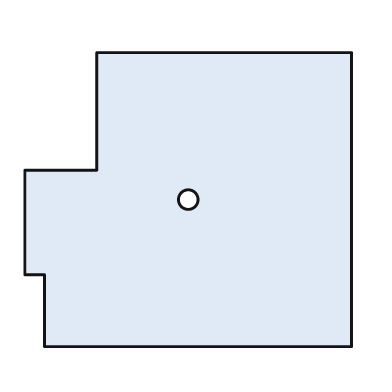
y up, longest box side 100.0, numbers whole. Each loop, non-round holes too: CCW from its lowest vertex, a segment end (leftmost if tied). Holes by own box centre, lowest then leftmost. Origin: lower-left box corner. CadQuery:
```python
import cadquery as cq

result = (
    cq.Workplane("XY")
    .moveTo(6.0, 0.0)
    .lineTo(100.0, 0.0)
    .lineTo(100.0, 90.0)
    .lineTo(22.0, 90.0)
    .lineTo(22.0, 54.0)
    .lineTo(0.0, 54.0)
    .lineTo(0.0, 22.0)
    .lineTo(6.0, 22.0)
    .close()
    .moveTo(50.0, 45.0)
    .circle(3.0)
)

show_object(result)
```